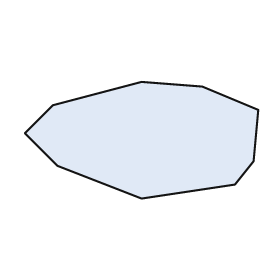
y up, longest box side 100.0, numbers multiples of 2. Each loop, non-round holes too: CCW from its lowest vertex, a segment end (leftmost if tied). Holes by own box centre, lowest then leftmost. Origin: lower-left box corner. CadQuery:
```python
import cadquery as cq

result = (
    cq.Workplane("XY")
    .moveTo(50.0, 0.0)
    .lineTo(90.0, 6.0)
    .lineTo(98.0, 16.0)
    .lineTo(100.0, 38.0)
    .lineTo(76.0, 48.0)
    .lineTo(50.0, 50.0)
    .lineTo(12.0, 40.0)
    .lineTo(0.0, 28.0)
    .lineTo(14.0, 14.0)
    .close()
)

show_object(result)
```